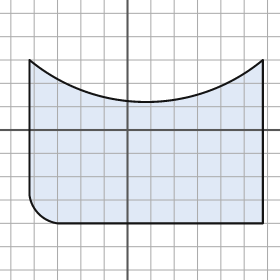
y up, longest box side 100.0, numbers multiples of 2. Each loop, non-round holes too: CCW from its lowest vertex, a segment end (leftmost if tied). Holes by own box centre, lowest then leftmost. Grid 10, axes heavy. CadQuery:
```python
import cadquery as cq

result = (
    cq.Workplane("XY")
    .moveTo(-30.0, -40.0)
    .lineTo(58.0, -40.0)
    .lineTo(58.0, 30.0)
    .threePointArc((8.0, 12.0), (-42.0, 30.0))
    .lineTo(-42.0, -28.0)
    .threePointArc((-38.0, -36.0), (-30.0, -40.0))
    .close()
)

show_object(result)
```